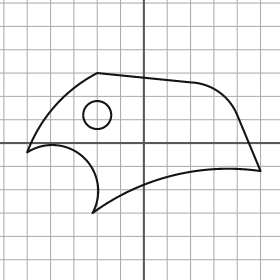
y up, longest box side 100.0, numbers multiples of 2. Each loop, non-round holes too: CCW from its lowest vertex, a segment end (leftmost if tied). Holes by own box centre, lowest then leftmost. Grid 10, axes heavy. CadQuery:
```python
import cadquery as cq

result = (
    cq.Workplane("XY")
    .moveTo(-22.0, -30.0)
    .threePointArc((12.0, -14.0), (50.0, -12.0))
    .lineTo(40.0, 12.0)
    .threePointArc((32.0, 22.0), (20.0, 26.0))
    .lineTo(-20.0, 30.0)
    .threePointArc((-38.0, 16.0), (-50.0, -4.0))
    .threePointArc((-26.0, -6.0), (-22.0, -30.0))
    .close()
    .moveTo(-20.0, 12.0)
    .circle(6.0)
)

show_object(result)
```